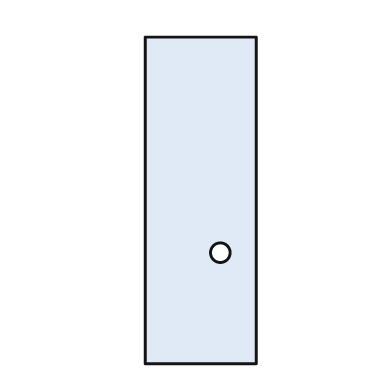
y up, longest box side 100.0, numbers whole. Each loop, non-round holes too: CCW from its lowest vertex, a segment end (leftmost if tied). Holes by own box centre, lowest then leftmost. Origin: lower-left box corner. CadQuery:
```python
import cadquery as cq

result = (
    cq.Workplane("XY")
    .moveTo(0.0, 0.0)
    .lineTo(34.0, 0.0)
    .lineTo(34.0, 100.0)
    .lineTo(0.0, 100.0)
    .close()
    .moveTo(23.0, 34.0)
    .circle(3.0)
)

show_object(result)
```